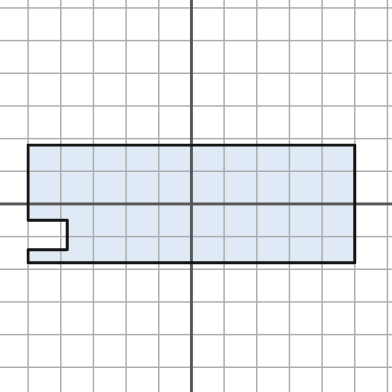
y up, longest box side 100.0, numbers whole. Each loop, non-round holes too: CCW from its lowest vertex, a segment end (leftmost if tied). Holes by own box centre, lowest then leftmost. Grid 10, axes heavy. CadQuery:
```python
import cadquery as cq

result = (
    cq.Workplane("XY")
    .moveTo(-50.0, -18.0)
    .lineTo(50.0, -18.0)
    .lineTo(50.0, 18.0)
    .lineTo(-50.0, 18.0)
    .lineTo(-50.0, -5.0)
    .lineTo(-38.0, -5.0)
    .lineTo(-38.0, -14.0)
    .lineTo(-50.0, -14.0)
    .close()
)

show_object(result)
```